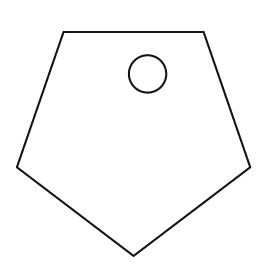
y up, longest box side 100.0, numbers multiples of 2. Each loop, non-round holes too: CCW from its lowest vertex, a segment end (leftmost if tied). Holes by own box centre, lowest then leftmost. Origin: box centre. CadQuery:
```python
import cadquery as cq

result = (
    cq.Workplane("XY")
    .moveTo(0.0, -48.0)
    .lineTo(50.0, -10.0)
    .lineTo(30.0, 48.0)
    .lineTo(-30.0, 48.0)
    .lineTo(-50.0, -10.0)
    .close()
    .moveTo(6.0, 30.0)
    .circle(8.0)
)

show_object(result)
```